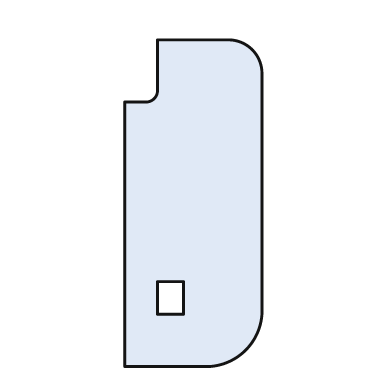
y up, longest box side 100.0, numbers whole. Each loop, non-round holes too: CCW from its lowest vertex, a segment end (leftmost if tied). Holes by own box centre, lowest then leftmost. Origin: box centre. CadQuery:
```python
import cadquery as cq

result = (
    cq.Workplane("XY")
    .moveTo(-21.0, -50.0)
    .lineTo(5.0, -50.0)
    .threePointArc((16.0, -45.0), (21.0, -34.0))
    .lineTo(21.0, 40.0)
    .threePointArc((18.0, 47.0), (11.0, 50.0))
    .lineTo(-11.0, 50.0)
    .lineTo(-11.0, 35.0)
    .threePointArc((-12.0, 32.0), (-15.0, 31.0))
    .lineTo(-21.0, 31.0)
    .close()
    .moveTo(-11.0, -34.0)
    .lineTo(-3.0, -34.0)
    .lineTo(-3.0, -24.0)
    .lineTo(-11.0, -24.0)
    .close()
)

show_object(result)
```